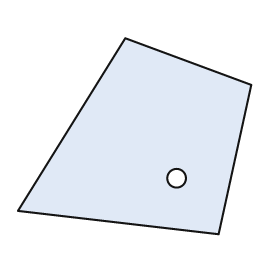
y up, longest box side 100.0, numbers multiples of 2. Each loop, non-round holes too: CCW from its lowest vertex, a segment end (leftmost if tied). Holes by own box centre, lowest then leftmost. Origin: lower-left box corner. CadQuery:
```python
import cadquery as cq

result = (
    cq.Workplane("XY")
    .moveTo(86.0, 0.0)
    .lineTo(100.0, 64.0)
    .lineTo(46.0, 84.0)
    .lineTo(0.0, 10.0)
    .close()
    .moveTo(68.0, 24.0)
    .circle(4.0)
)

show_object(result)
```